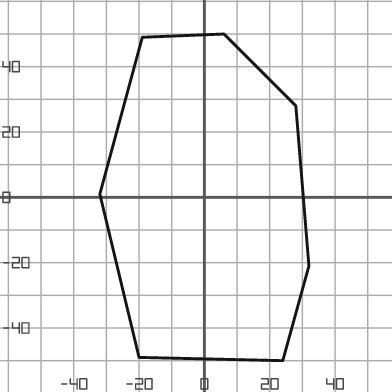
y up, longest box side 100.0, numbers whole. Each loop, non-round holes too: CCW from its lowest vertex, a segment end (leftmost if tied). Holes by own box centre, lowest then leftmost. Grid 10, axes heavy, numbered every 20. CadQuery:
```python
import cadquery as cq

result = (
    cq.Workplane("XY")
    .moveTo(24.0, -50.0)
    .lineTo(32.0, -21.0)
    .lineTo(28.0, 28.0)
    .lineTo(6.0, 50.0)
    .lineTo(-19.0, 49.0)
    .lineTo(-32.0, 1.0)
    .lineTo(-20.0, -49.0)
    .close()
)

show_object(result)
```